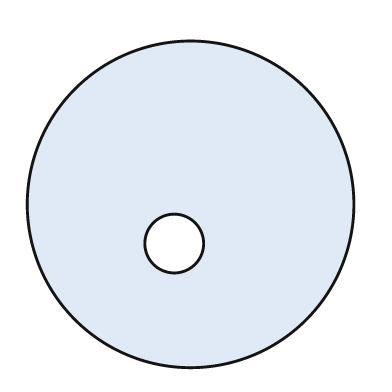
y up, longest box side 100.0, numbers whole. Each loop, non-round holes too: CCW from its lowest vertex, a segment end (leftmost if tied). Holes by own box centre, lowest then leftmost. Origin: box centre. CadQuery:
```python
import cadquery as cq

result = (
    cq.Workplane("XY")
    .moveTo(0.0, 0.0)
    .circle(50.0)
    .moveTo(-5.0, -12.0)
    .circle(9.0)
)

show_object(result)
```